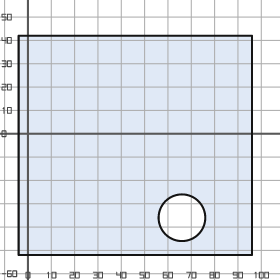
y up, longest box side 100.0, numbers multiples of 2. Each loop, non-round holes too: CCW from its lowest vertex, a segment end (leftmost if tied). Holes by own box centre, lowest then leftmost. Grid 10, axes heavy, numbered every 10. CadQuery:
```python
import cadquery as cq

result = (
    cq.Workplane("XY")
    .moveTo(-4.0, -52.0)
    .lineTo(96.0, -52.0)
    .lineTo(96.0, 42.0)
    .lineTo(-4.0, 42.0)
    .close()
    .moveTo(66.0, -36.0)
    .circle(10.0)
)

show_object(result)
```